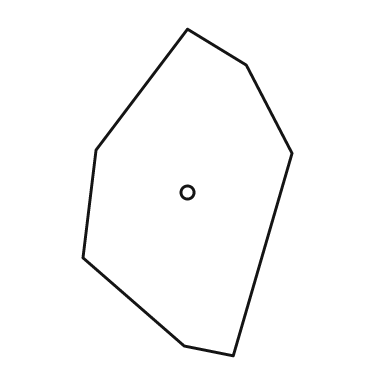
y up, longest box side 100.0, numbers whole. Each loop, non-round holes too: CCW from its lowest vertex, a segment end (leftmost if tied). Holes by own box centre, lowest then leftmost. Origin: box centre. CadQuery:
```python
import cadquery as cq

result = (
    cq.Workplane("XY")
    .moveTo(14.0, -50.0)
    .lineTo(32.0, 12.0)
    .lineTo(18.0, 39.0)
    .lineTo(0.0, 50.0)
    .lineTo(-28.0, 13.0)
    .lineTo(-32.0, -20.0)
    .lineTo(-1.0, -47.0)
    .close()
    .moveTo(0.0, 0.0)
    .circle(2.0)
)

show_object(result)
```